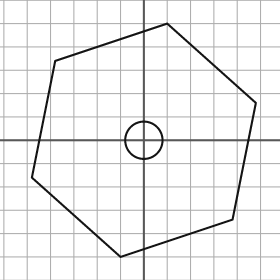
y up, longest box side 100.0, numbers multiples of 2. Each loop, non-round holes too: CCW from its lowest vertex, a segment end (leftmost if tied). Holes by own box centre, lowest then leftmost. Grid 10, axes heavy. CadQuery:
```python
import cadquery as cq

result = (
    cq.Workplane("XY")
    .moveTo(-10.0, -50.0)
    .lineTo(38.0, -34.0)
    .lineTo(48.0, 16.0)
    .lineTo(10.0, 50.0)
    .lineTo(-38.0, 34.0)
    .lineTo(-48.0, -16.0)
    .close()
    .moveTo(0.0, 0.0)
    .circle(8.0)
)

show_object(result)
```